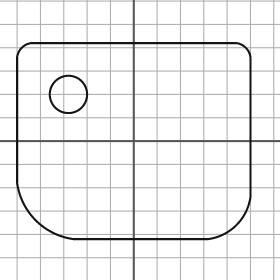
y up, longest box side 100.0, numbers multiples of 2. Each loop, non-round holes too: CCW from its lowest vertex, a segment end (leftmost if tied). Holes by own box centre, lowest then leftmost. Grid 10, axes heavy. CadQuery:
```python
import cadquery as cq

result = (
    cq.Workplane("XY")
    .moveTo(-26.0, -42.0)
    .lineTo(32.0, -42.0)
    .threePointArc((44.0, -36.0), (50.0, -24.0))
    .lineTo(50.0, 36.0)
    .threePointArc((48.0, 40.0), (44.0, 42.0))
    .lineTo(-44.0, 42.0)
    .threePointArc((-48.0, 40.0), (-50.0, 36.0))
    .lineTo(-50.0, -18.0)
    .threePointArc((-42.0, -34.0), (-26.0, -42.0))
    .close()
    .moveTo(-28.0, 20.0)
    .circle(8.0)
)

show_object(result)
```